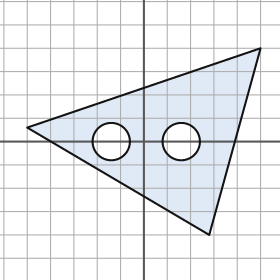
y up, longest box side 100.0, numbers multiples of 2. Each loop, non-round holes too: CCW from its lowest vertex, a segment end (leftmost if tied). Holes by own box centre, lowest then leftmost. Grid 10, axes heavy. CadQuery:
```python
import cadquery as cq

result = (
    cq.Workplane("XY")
    .moveTo(28.0, -40.0)
    .lineTo(50.0, 40.0)
    .lineTo(-50.0, 6.0)
    .close()
    .moveTo(-14.0, 0.0)
    .circle(8.0)
    .moveTo(16.0, 0.0)
    .circle(8.0)
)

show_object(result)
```